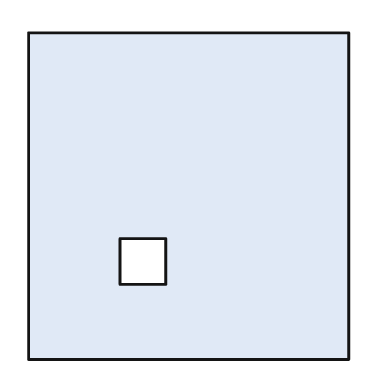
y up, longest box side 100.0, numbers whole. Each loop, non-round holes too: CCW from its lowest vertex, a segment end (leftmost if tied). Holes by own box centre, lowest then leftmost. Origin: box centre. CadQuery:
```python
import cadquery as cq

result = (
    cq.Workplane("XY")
    .moveTo(-49.0, -50.0)
    .lineTo(49.0, -50.0)
    .lineTo(49.0, 50.0)
    .lineTo(-49.0, 50.0)
    .close()
    .moveTo(-21.0, -27.0)
    .lineTo(-7.0, -27.0)
    .lineTo(-7.0, -13.0)
    .lineTo(-21.0, -13.0)
    .close()
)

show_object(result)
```